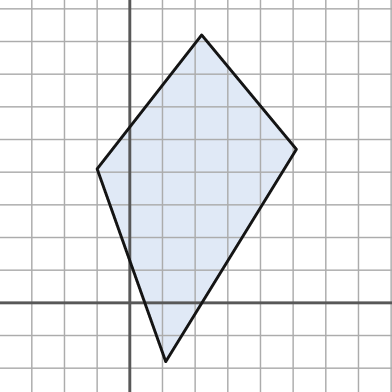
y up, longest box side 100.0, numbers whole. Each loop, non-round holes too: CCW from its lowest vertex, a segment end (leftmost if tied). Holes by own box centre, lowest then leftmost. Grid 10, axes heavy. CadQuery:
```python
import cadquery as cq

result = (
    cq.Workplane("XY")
    .moveTo(11.0, -18.0)
    .lineTo(51.0, 47.0)
    .lineTo(22.0, 82.0)
    .lineTo(-10.0, 41.0)
    .close()
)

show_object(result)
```